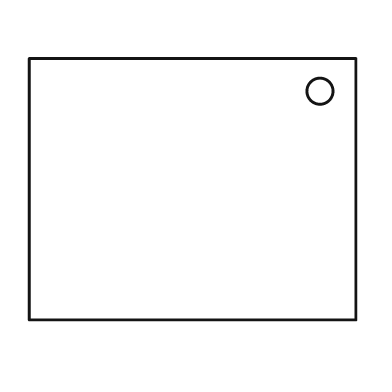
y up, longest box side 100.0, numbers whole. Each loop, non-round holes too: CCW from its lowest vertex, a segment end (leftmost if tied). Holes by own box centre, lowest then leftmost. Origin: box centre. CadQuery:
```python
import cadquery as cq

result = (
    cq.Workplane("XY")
    .moveTo(-50.0, -40.0)
    .lineTo(50.0, -40.0)
    .lineTo(50.0, 40.0)
    .lineTo(-50.0, 40.0)
    .close()
    .moveTo(39.0, 30.0)
    .circle(4.0)
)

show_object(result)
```